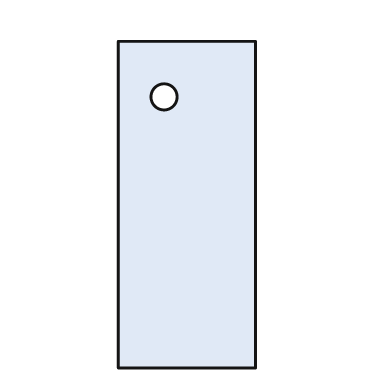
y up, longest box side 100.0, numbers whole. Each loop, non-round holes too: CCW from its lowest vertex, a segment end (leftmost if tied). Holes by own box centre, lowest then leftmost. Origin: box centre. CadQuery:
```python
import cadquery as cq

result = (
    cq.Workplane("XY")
    .moveTo(-21.0, -50.0)
    .lineTo(21.0, -50.0)
    .lineTo(21.0, 50.0)
    .lineTo(-21.0, 50.0)
    .close()
    .moveTo(-7.0, 33.0)
    .circle(4.0)
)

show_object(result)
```